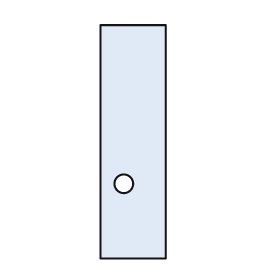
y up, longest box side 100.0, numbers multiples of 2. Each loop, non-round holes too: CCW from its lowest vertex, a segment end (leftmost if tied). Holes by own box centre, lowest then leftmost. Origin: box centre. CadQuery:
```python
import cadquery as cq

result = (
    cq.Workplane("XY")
    .moveTo(-14.0, -50.0)
    .lineTo(14.0, -50.0)
    .lineTo(14.0, 50.0)
    .lineTo(-14.0, 50.0)
    .close()
    .moveTo(-4.0, -18.0)
    .circle(4.0)
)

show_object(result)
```